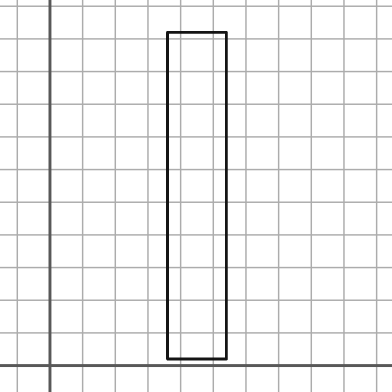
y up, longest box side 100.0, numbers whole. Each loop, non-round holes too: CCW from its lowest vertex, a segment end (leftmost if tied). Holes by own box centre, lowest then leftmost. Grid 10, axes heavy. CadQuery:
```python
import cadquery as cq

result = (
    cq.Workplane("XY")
    .moveTo(36.0, 2.0)
    .lineTo(54.0, 2.0)
    .lineTo(54.0, 102.0)
    .lineTo(36.0, 102.0)
    .close()
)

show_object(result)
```